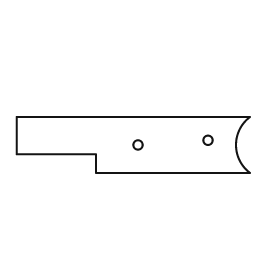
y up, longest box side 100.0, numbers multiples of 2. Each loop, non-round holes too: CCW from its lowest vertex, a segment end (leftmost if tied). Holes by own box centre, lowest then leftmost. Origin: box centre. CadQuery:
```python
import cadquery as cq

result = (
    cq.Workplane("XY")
    .moveTo(-16.0, -12.0)
    .lineTo(50.0, -12.0)
    .threePointArc((44.0, 0.0), (50.0, 12.0))
    .lineTo(-50.0, 12.0)
    .lineTo(-50.0, -4.0)
    .lineTo(-16.0, -4.0)
    .close()
    .moveTo(2.0, 0.0)
    .circle(2.0)
    .moveTo(32.0, 2.0)
    .circle(2.0)
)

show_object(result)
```